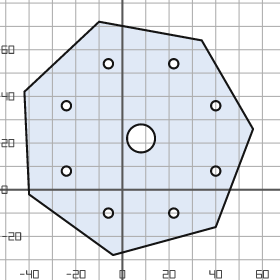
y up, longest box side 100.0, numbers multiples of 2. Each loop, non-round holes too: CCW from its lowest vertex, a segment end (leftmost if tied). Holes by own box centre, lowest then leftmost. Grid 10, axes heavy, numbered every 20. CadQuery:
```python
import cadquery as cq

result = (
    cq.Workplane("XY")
    .moveTo(-4.0, -28.0)
    .lineTo(40.0, -16.0)
    .lineTo(56.0, 26.0)
    .lineTo(34.0, 64.0)
    .lineTo(-10.0, 72.0)
    .lineTo(-42.0, 42.0)
    .lineTo(-40.0, -2.0)
    .close()
    .moveTo(-6.0, -10.0)
    .circle(2.0)
    .moveTo(22.0, -10.0)
    .circle(2.0)
    .moveTo(-24.0, 8.0)
    .circle(2.0)
    .moveTo(40.0, 8.0)
    .circle(2.0)
    .moveTo(8.0, 22.0)
    .circle(6.0)
    .moveTo(-24.0, 36.0)
    .circle(2.0)
    .moveTo(40.0, 36.0)
    .circle(2.0)
    .moveTo(-6.0, 54.0)
    .circle(2.0)
    .moveTo(22.0, 54.0)
    .circle(2.0)
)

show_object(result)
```